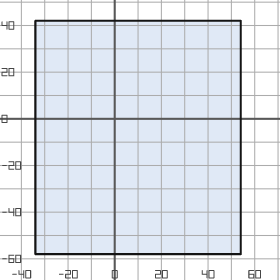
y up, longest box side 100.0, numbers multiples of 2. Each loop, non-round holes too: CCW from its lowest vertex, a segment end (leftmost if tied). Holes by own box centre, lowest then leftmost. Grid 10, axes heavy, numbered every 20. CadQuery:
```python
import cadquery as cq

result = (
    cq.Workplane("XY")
    .moveTo(-34.0, -58.0)
    .lineTo(54.0, -58.0)
    .lineTo(54.0, 42.0)
    .lineTo(-34.0, 42.0)
    .close()
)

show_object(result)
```